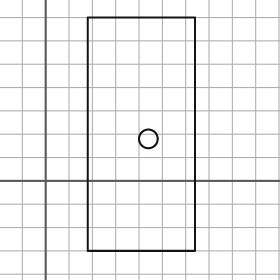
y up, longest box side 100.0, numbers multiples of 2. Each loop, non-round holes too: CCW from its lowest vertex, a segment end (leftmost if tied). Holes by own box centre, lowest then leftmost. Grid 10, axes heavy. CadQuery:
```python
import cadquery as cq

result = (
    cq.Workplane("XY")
    .moveTo(18.0, -30.0)
    .lineTo(64.0, -30.0)
    .lineTo(64.0, 70.0)
    .lineTo(18.0, 70.0)
    .close()
    .moveTo(44.0, 18.0)
    .circle(4.0)
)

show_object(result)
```